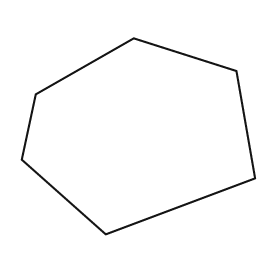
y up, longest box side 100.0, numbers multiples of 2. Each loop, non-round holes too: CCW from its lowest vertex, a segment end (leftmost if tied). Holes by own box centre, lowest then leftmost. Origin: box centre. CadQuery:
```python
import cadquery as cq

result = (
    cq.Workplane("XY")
    .moveTo(-14.0, -42.0)
    .lineTo(50.0, -18.0)
    .lineTo(42.0, 28.0)
    .lineTo(-2.0, 42.0)
    .lineTo(-44.0, 18.0)
    .lineTo(-50.0, -10.0)
    .close()
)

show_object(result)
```